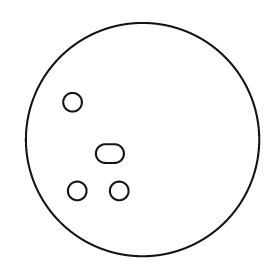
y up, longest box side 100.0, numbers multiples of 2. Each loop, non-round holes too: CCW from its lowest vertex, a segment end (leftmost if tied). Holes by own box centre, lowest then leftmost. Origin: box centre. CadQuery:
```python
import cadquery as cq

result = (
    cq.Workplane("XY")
    .moveTo(0.0, 0.0)
    .circle(50.0)
    .moveTo(-28.0, -22.0)
    .circle(4.0)
    .moveTo(-10.0, -22.0)
    .circle(4.0)
    .moveTo(-16.0, -10.0)
    .lineTo(-12.0, -10.0)
    .threePointArc((-8.0, -6.0), (-12.0, -2.0))
    .lineTo(-16.0, -2.0)
    .threePointArc((-20.0, -6.0), (-16.0, -10.0))
    .close()
    .moveTo(-30.0, 16.0)
    .circle(4.0)
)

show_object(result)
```